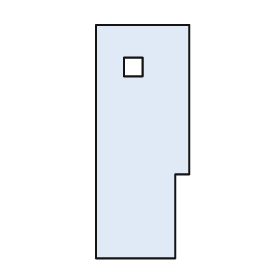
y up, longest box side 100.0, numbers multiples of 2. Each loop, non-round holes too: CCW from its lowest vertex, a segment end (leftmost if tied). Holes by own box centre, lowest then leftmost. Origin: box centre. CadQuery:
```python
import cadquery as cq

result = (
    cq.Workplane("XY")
    .moveTo(-20.0, -50.0)
    .lineTo(14.0, -50.0)
    .lineTo(14.0, -14.0)
    .lineTo(20.0, -14.0)
    .lineTo(20.0, 50.0)
    .lineTo(-20.0, 50.0)
    .close()
    .moveTo(-8.0, 28.0)
    .lineTo(0.0, 28.0)
    .lineTo(0.0, 36.0)
    .lineTo(-8.0, 36.0)
    .close()
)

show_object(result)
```